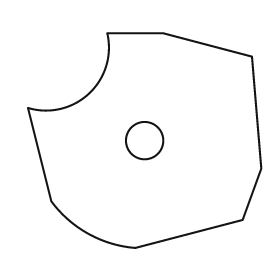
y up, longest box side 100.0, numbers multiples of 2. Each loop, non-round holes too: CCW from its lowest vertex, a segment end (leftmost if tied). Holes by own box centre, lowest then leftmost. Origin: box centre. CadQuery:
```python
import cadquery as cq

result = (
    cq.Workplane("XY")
    .moveTo(-4.0, -46.0)
    .lineTo(42.0, -34.0)
    .lineTo(50.0, -12.0)
    .lineTo(46.0, 36.0)
    .lineTo(8.0, 46.0)
    .lineTo(-16.0, 46.0)
    .threePointArc((-24.0, 20.0), (-50.0, 14.0))
    .lineTo(-40.0, -26.0)
    .threePointArc((-24.0, -40.0), (-4.0, -46.0))
    .close()
    .moveTo(0.0, 0.0)
    .circle(8.0)
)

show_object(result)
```